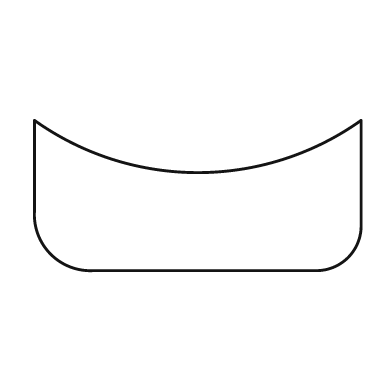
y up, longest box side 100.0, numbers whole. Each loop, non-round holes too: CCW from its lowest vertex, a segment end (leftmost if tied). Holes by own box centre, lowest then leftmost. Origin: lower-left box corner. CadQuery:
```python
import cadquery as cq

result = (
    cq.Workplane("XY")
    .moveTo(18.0, 0.0)
    .lineTo(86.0, 0.0)
    .threePointArc((96.0, 4.0), (100.0, 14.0))
    .lineTo(100.0, 46.0)
    .threePointArc((50.0, 30.0), (0.0, 46.0))
    .lineTo(0.0, 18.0)
    .threePointArc((5.0, 5.0), (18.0, 0.0))
    .close()
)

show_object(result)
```